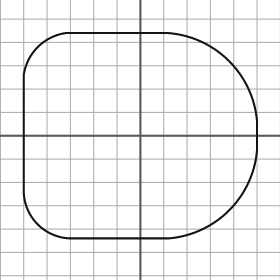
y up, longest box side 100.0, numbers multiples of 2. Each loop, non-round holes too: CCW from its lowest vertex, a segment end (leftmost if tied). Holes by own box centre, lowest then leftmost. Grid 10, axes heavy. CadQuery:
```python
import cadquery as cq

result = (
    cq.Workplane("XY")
    .moveTo(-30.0, -44.0)
    .lineTo(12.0, -44.0)
    .threePointArc((38.0, -32.0), (50.0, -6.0))
    .lineTo(50.0, 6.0)
    .threePointArc((38.0, 32.0), (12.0, 44.0))
    .lineTo(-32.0, 44.0)
    .threePointArc((-44.0, 38.0), (-50.0, 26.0))
    .lineTo(-50.0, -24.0)
    .threePointArc((-44.0, -38.0), (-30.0, -44.0))
    .close()
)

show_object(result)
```